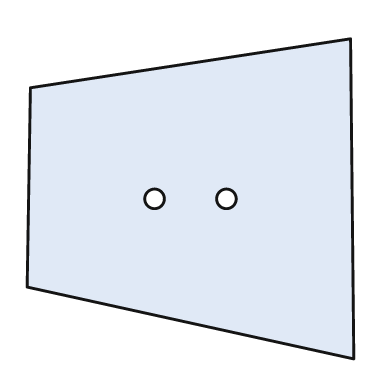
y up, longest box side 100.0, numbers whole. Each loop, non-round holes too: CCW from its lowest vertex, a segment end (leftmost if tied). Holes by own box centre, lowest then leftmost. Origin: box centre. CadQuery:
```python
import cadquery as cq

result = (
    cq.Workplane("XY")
    .moveTo(50.0, -49.0)
    .lineTo(49.0, 49.0)
    .lineTo(-49.0, 34.0)
    .lineTo(-50.0, -27.0)
    .close()
    .moveTo(-11.0, 0.0)
    .circle(3.0)
    .moveTo(11.0, 0.0)
    .circle(3.0)
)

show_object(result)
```